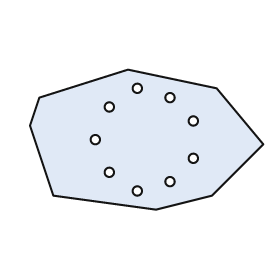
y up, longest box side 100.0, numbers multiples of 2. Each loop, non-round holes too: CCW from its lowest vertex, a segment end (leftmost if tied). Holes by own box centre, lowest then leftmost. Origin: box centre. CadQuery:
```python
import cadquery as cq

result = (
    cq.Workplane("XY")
    .moveTo(4.0, -30.0)
    .lineTo(28.0, -24.0)
    .lineTo(50.0, -2.0)
    .lineTo(30.0, 22.0)
    .lineTo(-8.0, 30.0)
    .lineTo(-46.0, 18.0)
    .lineTo(-50.0, 6.0)
    .lineTo(-40.0, -24.0)
    .close()
    .moveTo(-4.0, -22.0)
    .circle(2.0)
    .moveTo(10.0, -18.0)
    .circle(2.0)
    .moveTo(-16.0, -14.0)
    .circle(2.0)
    .moveTo(20.0, -8.0)
    .circle(2.0)
    .moveTo(-22.0, 0.0)
    .circle(2.0)
    .moveTo(20.0, 8.0)
    .circle(2.0)
    .moveTo(-16.0, 14.0)
    .circle(2.0)
    .moveTo(10.0, 18.0)
    .circle(2.0)
    .moveTo(-4.0, 22.0)
    .circle(2.0)
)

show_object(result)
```